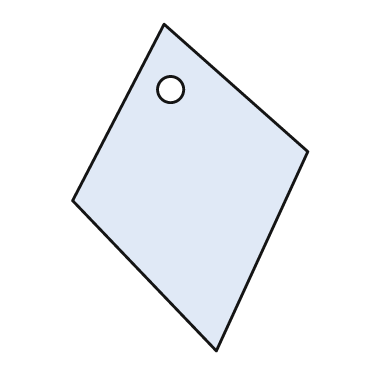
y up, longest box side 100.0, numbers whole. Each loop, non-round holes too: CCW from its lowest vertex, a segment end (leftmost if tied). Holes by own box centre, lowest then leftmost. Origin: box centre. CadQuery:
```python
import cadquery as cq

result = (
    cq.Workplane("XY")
    .moveTo(8.0, -50.0)
    .lineTo(36.0, 11.0)
    .lineTo(-8.0, 50.0)
    .lineTo(-36.0, -4.0)
    .close()
    .moveTo(-6.0, 30.0)
    .circle(4.0)
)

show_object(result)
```